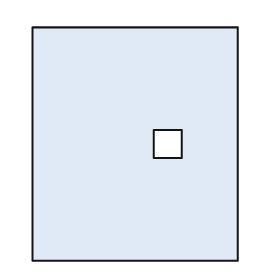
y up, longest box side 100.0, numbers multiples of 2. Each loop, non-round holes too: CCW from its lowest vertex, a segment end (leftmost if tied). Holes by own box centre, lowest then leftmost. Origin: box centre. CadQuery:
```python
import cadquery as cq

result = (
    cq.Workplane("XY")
    .moveTo(-44.0, -50.0)
    .lineTo(44.0, -50.0)
    .lineTo(44.0, 50.0)
    .lineTo(-44.0, 50.0)
    .close()
    .moveTo(8.0, -6.0)
    .lineTo(20.0, -6.0)
    .lineTo(20.0, 6.0)
    .lineTo(8.0, 6.0)
    .close()
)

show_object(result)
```